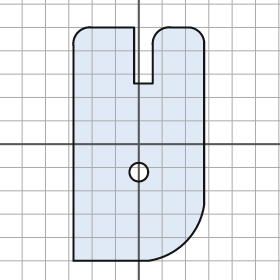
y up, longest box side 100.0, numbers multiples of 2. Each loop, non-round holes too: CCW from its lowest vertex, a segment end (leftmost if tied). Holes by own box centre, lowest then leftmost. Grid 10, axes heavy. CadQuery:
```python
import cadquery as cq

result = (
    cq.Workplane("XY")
    .moveTo(-28.0, -50.0)
    .lineTo(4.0, -50.0)
    .threePointArc((20.0, -42.0), (28.0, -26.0))
    .lineTo(28.0, 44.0)
    .threePointArc((26.0, 48.0), (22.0, 50.0))
    .lineTo(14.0, 50.0)
    .threePointArc((8.0, 48.0), (6.0, 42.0))
    .lineTo(6.0, 26.0)
    .lineTo(-2.0, 26.0)
    .lineTo(-2.0, 50.0)
    .lineTo(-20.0, 50.0)
    .threePointArc((-26.0, 48.0), (-28.0, 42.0))
    .close()
    .moveTo(0.0, -12.0)
    .circle(4.0)
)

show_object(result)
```